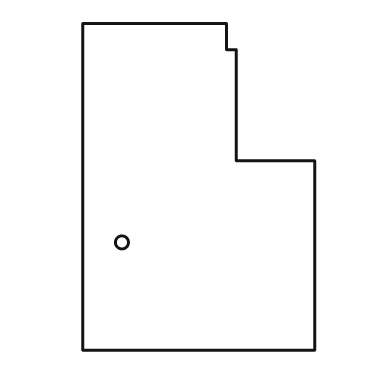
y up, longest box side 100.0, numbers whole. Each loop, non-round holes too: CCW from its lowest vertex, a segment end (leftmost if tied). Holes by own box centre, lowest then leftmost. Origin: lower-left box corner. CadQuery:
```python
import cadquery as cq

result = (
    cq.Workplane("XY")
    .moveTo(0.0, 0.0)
    .lineTo(71.0, 0.0)
    .lineTo(71.0, 58.0)
    .lineTo(47.0, 58.0)
    .lineTo(47.0, 92.0)
    .lineTo(44.0, 92.0)
    .lineTo(44.0, 100.0)
    .lineTo(0.0, 100.0)
    .close()
    .moveTo(12.0, 33.0)
    .circle(2.0)
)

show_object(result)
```